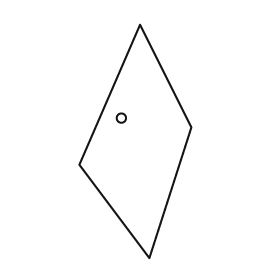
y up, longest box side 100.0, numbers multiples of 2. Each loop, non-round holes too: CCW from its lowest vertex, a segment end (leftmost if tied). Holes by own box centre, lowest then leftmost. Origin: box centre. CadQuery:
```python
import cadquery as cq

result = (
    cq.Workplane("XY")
    .moveTo(6.0, -50.0)
    .lineTo(24.0, 6.0)
    .lineTo(2.0, 50.0)
    .lineTo(-24.0, -10.0)
    .close()
    .moveTo(-6.0, 10.0)
    .circle(2.0)
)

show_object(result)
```